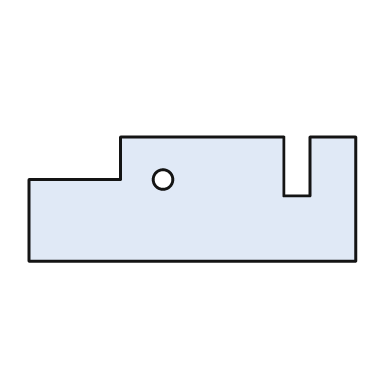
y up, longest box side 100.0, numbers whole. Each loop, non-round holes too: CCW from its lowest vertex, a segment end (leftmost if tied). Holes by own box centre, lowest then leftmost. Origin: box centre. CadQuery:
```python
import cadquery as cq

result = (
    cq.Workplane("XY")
    .moveTo(-50.0, -19.0)
    .lineTo(50.0, -19.0)
    .lineTo(50.0, 19.0)
    .lineTo(36.0, 19.0)
    .lineTo(36.0, 1.0)
    .lineTo(28.0, 1.0)
    .lineTo(28.0, 19.0)
    .lineTo(-22.0, 19.0)
    .lineTo(-22.0, 6.0)
    .lineTo(-50.0, 6.0)
    .close()
    .moveTo(-9.0, 6.0)
    .circle(3.0)
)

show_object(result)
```